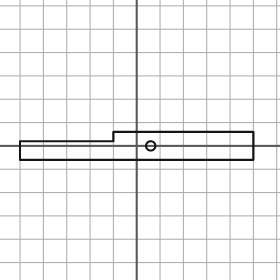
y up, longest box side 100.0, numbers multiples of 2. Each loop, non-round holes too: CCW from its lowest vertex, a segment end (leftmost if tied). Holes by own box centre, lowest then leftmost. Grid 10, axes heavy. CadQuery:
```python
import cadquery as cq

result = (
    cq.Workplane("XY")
    .moveTo(-50.0, -6.0)
    .lineTo(50.0, -6.0)
    .lineTo(50.0, 6.0)
    .lineTo(-10.0, 6.0)
    .lineTo(-10.0, 2.0)
    .lineTo(-50.0, 2.0)
    .close()
    .moveTo(6.0, 0.0)
    .circle(2.0)
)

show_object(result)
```